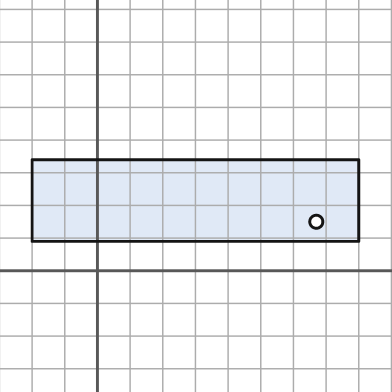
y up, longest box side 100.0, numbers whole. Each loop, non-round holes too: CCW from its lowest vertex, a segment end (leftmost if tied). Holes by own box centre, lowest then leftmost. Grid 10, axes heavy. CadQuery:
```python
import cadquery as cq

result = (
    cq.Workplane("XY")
    .moveTo(-20.0, 9.0)
    .lineTo(80.0, 9.0)
    .lineTo(80.0, 34.0)
    .lineTo(-20.0, 34.0)
    .close()
    .moveTo(67.0, 15.0)
    .circle(2.0)
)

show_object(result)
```